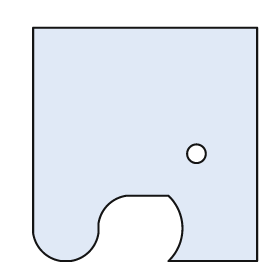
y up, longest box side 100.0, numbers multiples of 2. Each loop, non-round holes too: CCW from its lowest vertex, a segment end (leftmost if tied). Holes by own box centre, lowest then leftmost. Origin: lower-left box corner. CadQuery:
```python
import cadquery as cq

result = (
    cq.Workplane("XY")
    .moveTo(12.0, 0.0)
    .lineTo(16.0, 0.0)
    .threePointArc((24.0, 4.0), (28.0, 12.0))
    .lineTo(28.0, 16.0)
    .threePointArc((32.0, 24.0), (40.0, 28.0))
    .lineTo(58.0, 28.0)
    .threePointArc((64.0, 14.0), (58.0, 0.0))
    .lineTo(96.0, 0.0)
    .lineTo(96.0, 100.0)
    .lineTo(0.0, 100.0)
    .lineTo(0.0, 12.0)
    .threePointArc((4.0, 4.0), (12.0, 0.0))
    .close()
    .moveTo(70.0, 46.0)
    .circle(4.0)
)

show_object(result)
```